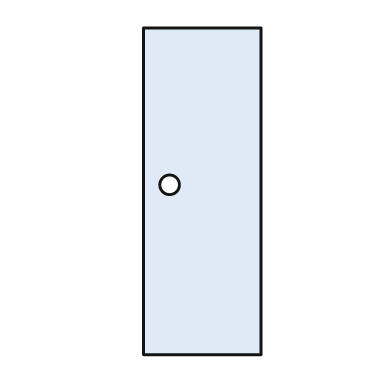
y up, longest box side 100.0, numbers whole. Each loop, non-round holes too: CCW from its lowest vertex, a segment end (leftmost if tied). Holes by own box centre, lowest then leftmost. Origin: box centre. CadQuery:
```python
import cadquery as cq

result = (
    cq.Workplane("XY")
    .moveTo(-18.0, -50.0)
    .lineTo(18.0, -50.0)
    .lineTo(18.0, 50.0)
    .lineTo(-18.0, 50.0)
    .close()
    .moveTo(-10.0, 2.0)
    .circle(3.0)
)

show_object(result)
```